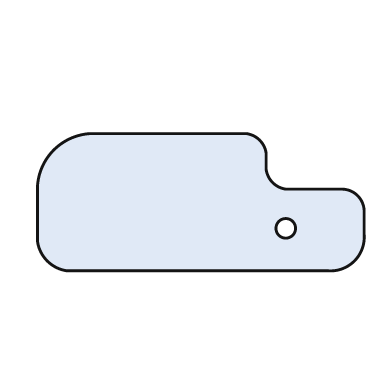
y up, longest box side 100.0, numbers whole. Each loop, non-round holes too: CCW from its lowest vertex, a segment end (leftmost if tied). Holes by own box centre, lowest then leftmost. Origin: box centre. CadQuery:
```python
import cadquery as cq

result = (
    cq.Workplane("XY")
    .moveTo(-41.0, -21.0)
    .lineTo(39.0, -21.0)
    .threePointArc((47.0, -18.0), (50.0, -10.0))
    .lineTo(50.0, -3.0)
    .threePointArc((48.0, 2.0), (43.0, 4.0))
    .lineTo(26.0, 4.0)
    .threePointArc((22.0, 6.0), (20.0, 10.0))
    .lineTo(20.0, 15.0)
    .threePointArc((18.0, 19.0), (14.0, 21.0))
    .lineTo(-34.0, 21.0)
    .threePointArc((-45.0, 16.0), (-50.0, 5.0))
    .lineTo(-50.0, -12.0)
    .threePointArc((-47.0, -18.0), (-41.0, -21.0))
    .close()
    .moveTo(26.0, -8.0)
    .circle(3.0)
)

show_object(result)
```